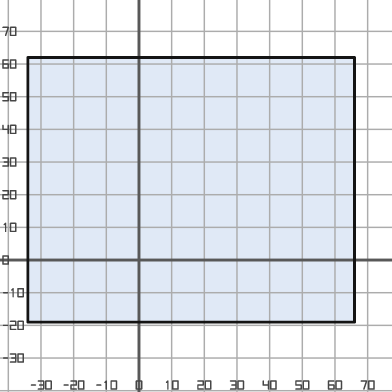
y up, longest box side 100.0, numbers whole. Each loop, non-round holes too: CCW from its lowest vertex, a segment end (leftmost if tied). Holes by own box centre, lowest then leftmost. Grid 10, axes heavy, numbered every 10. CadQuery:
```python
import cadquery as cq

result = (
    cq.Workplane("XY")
    .moveTo(-34.0, -19.0)
    .lineTo(66.0, -19.0)
    .lineTo(66.0, 62.0)
    .lineTo(-34.0, 62.0)
    .close()
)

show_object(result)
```